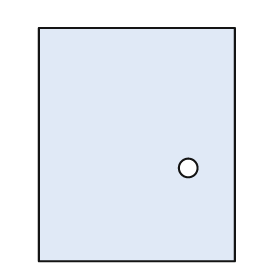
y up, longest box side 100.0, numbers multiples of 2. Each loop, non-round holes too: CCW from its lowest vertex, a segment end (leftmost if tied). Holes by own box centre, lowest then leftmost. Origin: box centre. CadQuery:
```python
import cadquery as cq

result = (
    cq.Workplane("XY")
    .moveTo(-42.0, -50.0)
    .lineTo(42.0, -50.0)
    .lineTo(42.0, 50.0)
    .lineTo(-42.0, 50.0)
    .close()
    .moveTo(22.0, -10.0)
    .circle(4.0)
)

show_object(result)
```